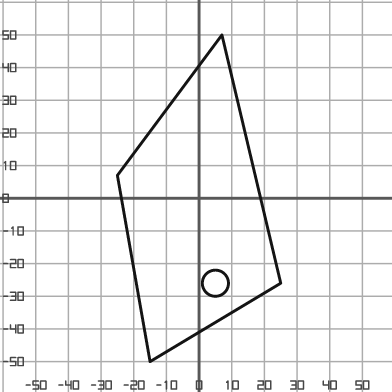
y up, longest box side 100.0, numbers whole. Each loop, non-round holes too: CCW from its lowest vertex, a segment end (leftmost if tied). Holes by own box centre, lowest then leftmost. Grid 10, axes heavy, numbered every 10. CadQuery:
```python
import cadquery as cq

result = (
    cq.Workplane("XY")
    .moveTo(-15.0, -50.0)
    .lineTo(25.0, -26.0)
    .lineTo(7.0, 50.0)
    .lineTo(-25.0, 7.0)
    .close()
    .moveTo(5.0, -26.0)
    .circle(4.0)
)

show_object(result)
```